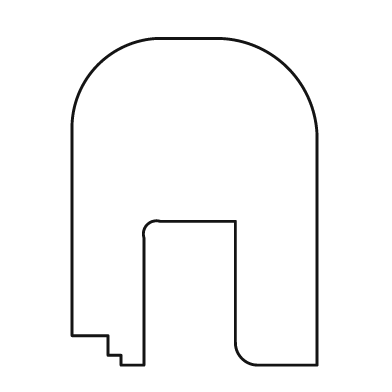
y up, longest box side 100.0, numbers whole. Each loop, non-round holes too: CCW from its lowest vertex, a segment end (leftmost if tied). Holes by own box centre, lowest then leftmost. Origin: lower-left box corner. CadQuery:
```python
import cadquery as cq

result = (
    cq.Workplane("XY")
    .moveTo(15.0, 0.0)
    .lineTo(22.0, 0.0)
    .lineTo(22.0, 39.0)
    .threePointArc((23.0, 43.0), (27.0, 44.0))
    .lineTo(50.0, 44.0)
    .lineTo(50.0, 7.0)
    .threePointArc((52.0, 2.0), (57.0, 0.0))
    .lineTo(75.0, 0.0)
    .lineTo(75.0, 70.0)
    .threePointArc((66.0, 91.0), (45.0, 100.0))
    .lineTo(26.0, 100.0)
    .threePointArc((8.0, 92.0), (0.0, 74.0))
    .lineTo(0.0, 9.0)
    .lineTo(11.0, 9.0)
    .lineTo(11.0, 3.0)
    .lineTo(15.0, 3.0)
    .close()
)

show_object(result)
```